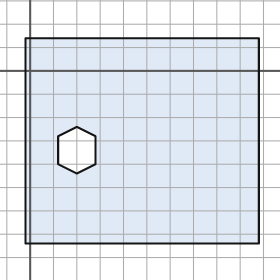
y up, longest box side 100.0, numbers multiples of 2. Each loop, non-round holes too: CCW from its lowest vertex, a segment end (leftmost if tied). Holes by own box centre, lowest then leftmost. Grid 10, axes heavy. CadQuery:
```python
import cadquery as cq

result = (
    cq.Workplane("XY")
    .moveTo(-2.0, -74.0)
    .lineTo(98.0, -74.0)
    .lineTo(98.0, 14.0)
    .lineTo(-2.0, 14.0)
    .close()
    .moveTo(20.0, -44.0)
    .lineTo(28.0, -40.0)
    .lineTo(28.0, -28.0)
    .lineTo(20.0, -24.0)
    .lineTo(12.0, -28.0)
    .lineTo(12.0, -40.0)
    .close()
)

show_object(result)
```